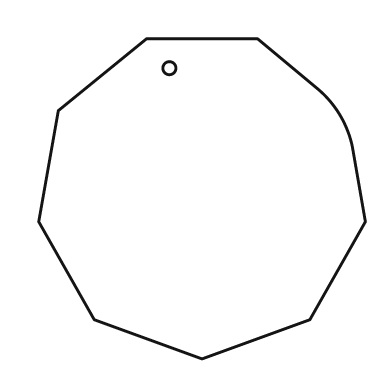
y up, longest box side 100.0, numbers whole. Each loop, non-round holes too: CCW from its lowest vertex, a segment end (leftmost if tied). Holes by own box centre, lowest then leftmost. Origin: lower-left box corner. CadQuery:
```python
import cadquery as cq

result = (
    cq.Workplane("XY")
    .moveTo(50.0, 0.0)
    .lineTo(83.0, 12.0)
    .lineTo(100.0, 42.0)
    .lineTo(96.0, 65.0)
    .threePointArc((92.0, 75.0), (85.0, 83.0))
    .lineTo(67.0, 98.0)
    .lineTo(33.0, 98.0)
    .lineTo(6.0, 76.0)
    .lineTo(0.0, 42.0)
    .lineTo(17.0, 12.0)
    .close()
    .moveTo(40.0, 89.0)
    .circle(2.0)
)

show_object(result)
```